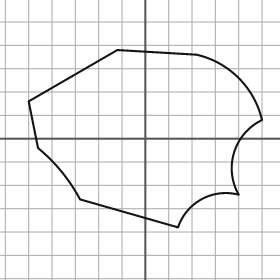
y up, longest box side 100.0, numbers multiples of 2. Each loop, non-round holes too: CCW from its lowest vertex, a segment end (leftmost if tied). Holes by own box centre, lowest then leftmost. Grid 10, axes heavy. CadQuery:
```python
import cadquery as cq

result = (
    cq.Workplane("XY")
    .moveTo(14.0, -38.0)
    .threePointArc((24.0, -26.0), (40.0, -24.0))
    .threePointArc((38.0, -6.0), (50.0, 8.0))
    .threePointArc((40.0, 26.0), (22.0, 36.0))
    .lineTo(-12.0, 38.0)
    .lineTo(-50.0, 16.0)
    .lineTo(-46.0, -4.0)
    .threePointArc((-36.0, -14.0), (-28.0, -26.0))
    .close()
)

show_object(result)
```